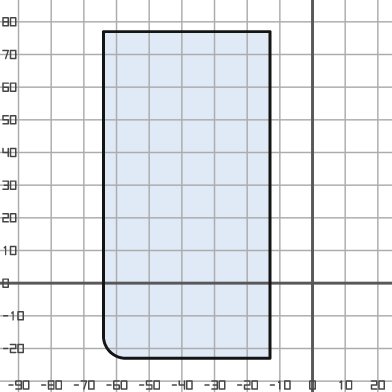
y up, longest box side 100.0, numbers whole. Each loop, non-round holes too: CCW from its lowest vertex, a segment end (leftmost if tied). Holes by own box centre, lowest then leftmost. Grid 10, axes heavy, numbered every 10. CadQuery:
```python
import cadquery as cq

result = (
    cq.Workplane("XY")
    .moveTo(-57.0, -23.0)
    .lineTo(-13.0, -23.0)
    .lineTo(-13.0, 77.0)
    .lineTo(-64.0, 77.0)
    .lineTo(-64.0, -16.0)
    .threePointArc((-62.0, -21.0), (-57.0, -23.0))
    .close()
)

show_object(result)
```